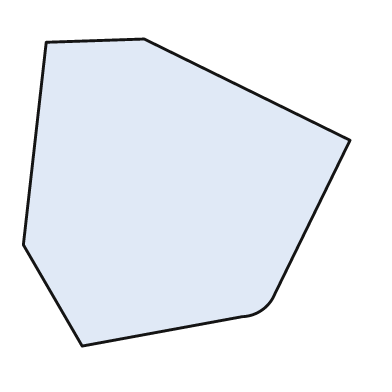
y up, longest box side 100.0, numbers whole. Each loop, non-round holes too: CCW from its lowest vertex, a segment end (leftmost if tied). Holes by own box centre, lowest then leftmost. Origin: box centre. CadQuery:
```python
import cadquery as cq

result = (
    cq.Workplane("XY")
    .moveTo(-32.0, -47.0)
    .lineTo(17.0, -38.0)
    .threePointArc((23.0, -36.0), (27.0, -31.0))
    .lineTo(50.0, 16.0)
    .lineTo(-13.0, 47.0)
    .lineTo(-43.0, 46.0)
    .lineTo(-50.0, -16.0)
    .close()
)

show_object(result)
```